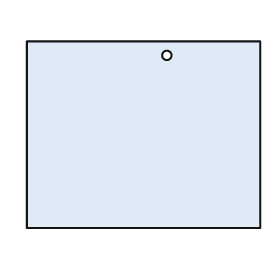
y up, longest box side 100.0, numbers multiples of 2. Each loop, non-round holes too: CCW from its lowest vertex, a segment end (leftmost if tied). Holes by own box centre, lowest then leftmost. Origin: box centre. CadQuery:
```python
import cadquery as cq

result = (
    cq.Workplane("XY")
    .moveTo(-50.0, -40.0)
    .lineTo(50.0, -40.0)
    .lineTo(50.0, 40.0)
    .lineTo(-50.0, 40.0)
    .close()
    .moveTo(10.0, 34.0)
    .circle(2.0)
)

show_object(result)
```